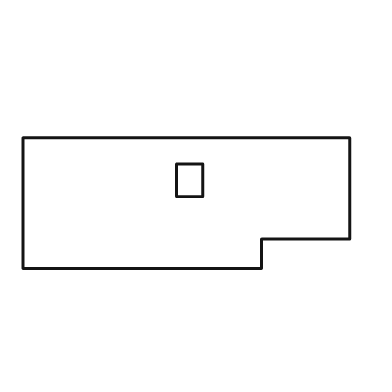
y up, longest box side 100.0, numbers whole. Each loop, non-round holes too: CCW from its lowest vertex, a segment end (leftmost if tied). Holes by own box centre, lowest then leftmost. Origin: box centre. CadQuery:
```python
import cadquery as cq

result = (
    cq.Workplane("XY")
    .moveTo(-50.0, -20.0)
    .lineTo(23.0, -20.0)
    .lineTo(23.0, -11.0)
    .lineTo(50.0, -11.0)
    .lineTo(50.0, 20.0)
    .lineTo(-50.0, 20.0)
    .close()
    .moveTo(-3.0, 2.0)
    .lineTo(5.0, 2.0)
    .lineTo(5.0, 12.0)
    .lineTo(-3.0, 12.0)
    .close()
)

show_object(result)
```